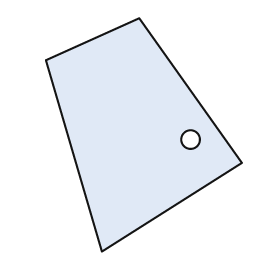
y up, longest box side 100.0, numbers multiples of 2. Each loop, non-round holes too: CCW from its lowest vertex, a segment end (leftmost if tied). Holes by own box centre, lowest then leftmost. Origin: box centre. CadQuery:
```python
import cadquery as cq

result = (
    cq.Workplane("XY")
    .moveTo(-18.0, -50.0)
    .lineTo(42.0, -12.0)
    .lineTo(-2.0, 50.0)
    .lineTo(-42.0, 32.0)
    .close()
    .moveTo(20.0, -2.0)
    .circle(4.0)
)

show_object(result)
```